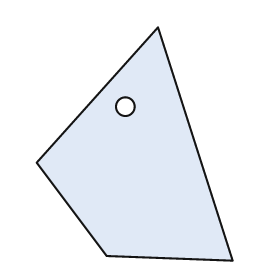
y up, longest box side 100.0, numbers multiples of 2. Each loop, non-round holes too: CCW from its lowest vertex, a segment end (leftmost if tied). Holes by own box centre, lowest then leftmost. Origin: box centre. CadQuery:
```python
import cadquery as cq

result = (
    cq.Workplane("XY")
    .moveTo(42.0, -50.0)
    .lineTo(10.0, 50.0)
    .lineTo(-42.0, -8.0)
    .lineTo(-12.0, -48.0)
    .close()
    .moveTo(-4.0, 16.0)
    .circle(4.0)
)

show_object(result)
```